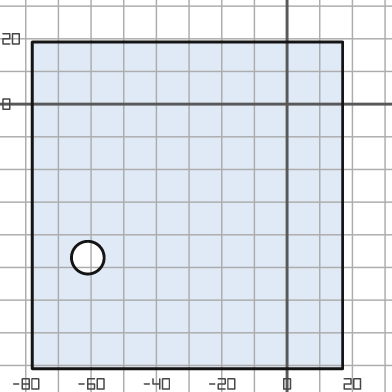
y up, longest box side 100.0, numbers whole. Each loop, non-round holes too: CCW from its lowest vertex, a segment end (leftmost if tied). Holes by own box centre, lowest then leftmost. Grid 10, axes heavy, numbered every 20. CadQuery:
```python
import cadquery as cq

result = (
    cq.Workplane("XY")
    .moveTo(-78.0, -81.0)
    .lineTo(17.0, -81.0)
    .lineTo(17.0, 19.0)
    .lineTo(-78.0, 19.0)
    .close()
    .moveTo(-61.0, -47.0)
    .circle(5.0)
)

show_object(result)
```